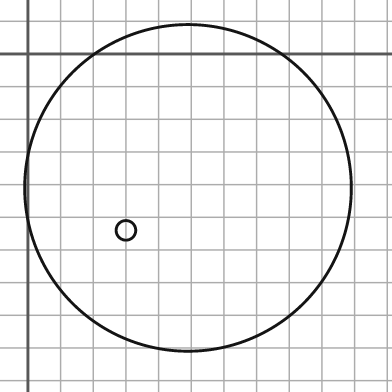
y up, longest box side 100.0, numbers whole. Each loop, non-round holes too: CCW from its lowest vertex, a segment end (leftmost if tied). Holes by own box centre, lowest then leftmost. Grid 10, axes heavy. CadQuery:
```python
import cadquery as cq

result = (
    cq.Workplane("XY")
    .moveTo(49.0, -41.0)
    .circle(50.0)
    .moveTo(30.0, -54.0)
    .circle(3.0)
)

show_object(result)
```